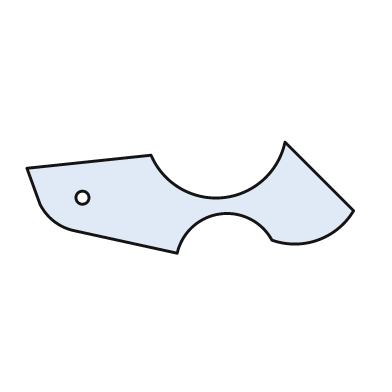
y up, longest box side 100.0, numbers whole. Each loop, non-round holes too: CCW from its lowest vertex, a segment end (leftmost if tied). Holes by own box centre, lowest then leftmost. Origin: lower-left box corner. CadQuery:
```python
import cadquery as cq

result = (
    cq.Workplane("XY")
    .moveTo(46.0, 0.0)
    .threePointArc((59.0, 12.0), (75.0, 4.0))
    .threePointArc((89.0, 4.0), (100.0, 13.0))
    .lineTo(79.0, 34.0)
    .threePointArc((60.0, 17.0), (38.0, 30.0))
    .lineTo(0.0, 26.0)
    .lineTo(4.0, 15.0)
    .threePointArc((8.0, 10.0), (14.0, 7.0))
    .close()
    .moveTo(17.0, 17.0)
    .circle(2.0)
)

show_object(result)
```